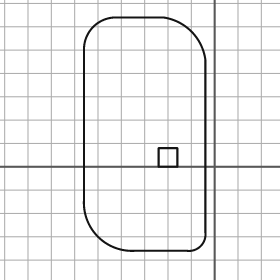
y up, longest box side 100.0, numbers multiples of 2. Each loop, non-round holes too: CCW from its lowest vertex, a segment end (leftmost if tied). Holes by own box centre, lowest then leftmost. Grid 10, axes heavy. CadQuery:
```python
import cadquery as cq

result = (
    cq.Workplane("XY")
    .moveTo(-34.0, -36.0)
    .lineTo(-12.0, -36.0)
    .threePointArc((-6.0, -34.0), (-4.0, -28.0))
    .lineTo(-4.0, 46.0)
    .threePointArc((-10.0, 58.0), (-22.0, 64.0))
    .lineTo(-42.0, 64.0)
    .threePointArc((-52.0, 60.0), (-56.0, 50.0))
    .lineTo(-56.0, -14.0)
    .threePointArc((-50.0, -30.0), (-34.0, -36.0))
    .close()
    .moveTo(-24.0, 0.0)
    .lineTo(-16.0, 0.0)
    .lineTo(-16.0, 8.0)
    .lineTo(-24.0, 8.0)
    .close()
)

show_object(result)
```